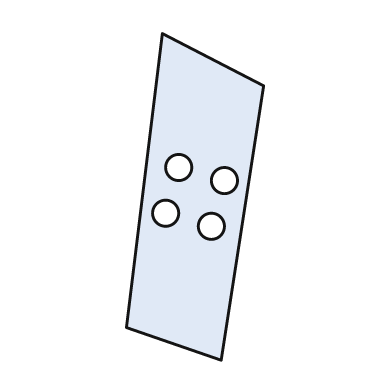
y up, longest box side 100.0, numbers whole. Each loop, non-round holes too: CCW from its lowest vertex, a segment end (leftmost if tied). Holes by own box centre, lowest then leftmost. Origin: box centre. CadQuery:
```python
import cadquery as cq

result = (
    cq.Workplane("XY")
    .moveTo(8.0, -50.0)
    .lineTo(21.0, 34.0)
    .lineTo(-10.0, 50.0)
    .lineTo(-21.0, -40.0)
    .close()
    .moveTo(5.0, -9.0)
    .circle(4.0)
    .moveTo(-9.0, -5.0)
    .circle(4.0)
    .moveTo(9.0, 5.0)
    .circle(4.0)
    .moveTo(-5.0, 9.0)
    .circle(4.0)
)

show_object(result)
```